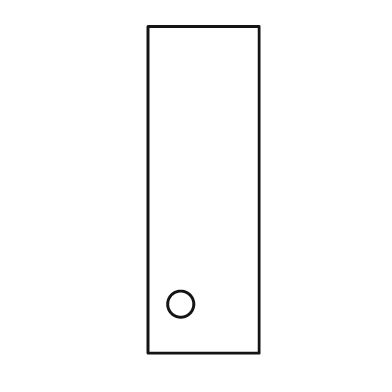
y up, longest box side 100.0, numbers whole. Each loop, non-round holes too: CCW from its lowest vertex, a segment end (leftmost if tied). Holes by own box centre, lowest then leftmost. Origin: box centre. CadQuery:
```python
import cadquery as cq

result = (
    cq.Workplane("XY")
    .moveTo(-17.0, -50.0)
    .lineTo(17.0, -50.0)
    .lineTo(17.0, 50.0)
    .lineTo(-17.0, 50.0)
    .close()
    .moveTo(-7.0, -35.0)
    .circle(4.0)
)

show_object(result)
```